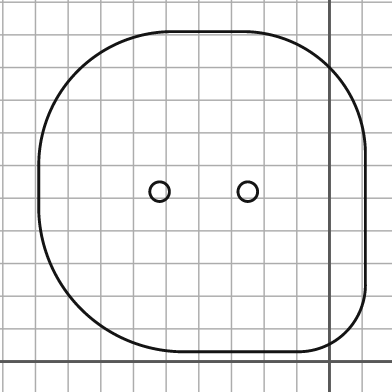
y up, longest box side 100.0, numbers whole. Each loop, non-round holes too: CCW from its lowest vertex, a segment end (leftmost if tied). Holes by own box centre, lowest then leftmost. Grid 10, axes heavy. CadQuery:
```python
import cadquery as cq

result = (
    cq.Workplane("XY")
    .moveTo(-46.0, 3.0)
    .lineTo(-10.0, 3.0)
    .threePointArc((5.0, 9.0), (11.0, 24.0))
    .lineTo(11.0, 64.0)
    .threePointArc((0.0, 90.0), (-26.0, 101.0))
    .lineTo(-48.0, 101.0)
    .threePointArc((-77.0, 89.0), (-89.0, 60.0))
    .lineTo(-89.0, 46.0)
    .threePointArc((-76.0, 16.0), (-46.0, 3.0))
    .close()
    .moveTo(-52.0, 52.0)
    .circle(3.0)
    .moveTo(-25.0, 52.0)
    .circle(3.0)
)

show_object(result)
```